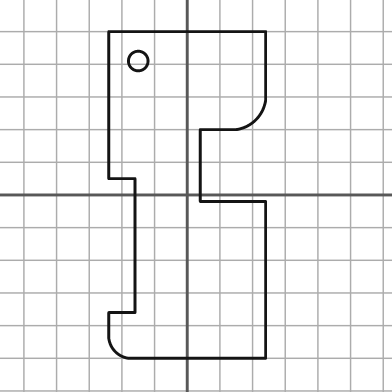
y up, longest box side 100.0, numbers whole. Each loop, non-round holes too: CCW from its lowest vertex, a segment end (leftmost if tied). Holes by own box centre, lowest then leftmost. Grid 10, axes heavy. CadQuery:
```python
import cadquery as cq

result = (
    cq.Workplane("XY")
    .moveTo(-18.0, -50.0)
    .lineTo(24.0, -50.0)
    .lineTo(24.0, -2.0)
    .lineTo(4.0, -2.0)
    .lineTo(4.0, 20.0)
    .lineTo(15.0, 20.0)
    .threePointArc((21.0, 23.0), (24.0, 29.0))
    .lineTo(24.0, 50.0)
    .lineTo(-24.0, 50.0)
    .lineTo(-24.0, 5.0)
    .lineTo(-16.0, 5.0)
    .lineTo(-16.0, -36.0)
    .lineTo(-24.0, -36.0)
    .lineTo(-24.0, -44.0)
    .threePointArc((-22.0, -48.0), (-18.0, -50.0))
    .close()
    .moveTo(-15.0, 41.0)
    .circle(3.0)
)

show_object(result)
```